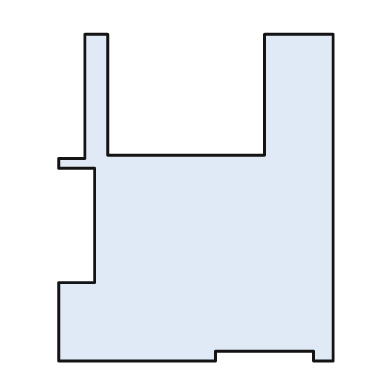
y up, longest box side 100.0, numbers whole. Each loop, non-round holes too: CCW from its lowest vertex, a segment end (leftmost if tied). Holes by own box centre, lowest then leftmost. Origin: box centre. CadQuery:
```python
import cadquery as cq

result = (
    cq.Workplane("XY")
    .moveTo(-42.0, -50.0)
    .lineTo(6.0, -50.0)
    .lineTo(6.0, -47.0)
    .lineTo(36.0, -47.0)
    .lineTo(36.0, -50.0)
    .lineTo(42.0, -50.0)
    .lineTo(42.0, 50.0)
    .lineTo(21.0, 50.0)
    .lineTo(21.0, 13.0)
    .lineTo(-27.0, 13.0)
    .lineTo(-27.0, 50.0)
    .lineTo(-34.0, 50.0)
    .lineTo(-34.0, 12.0)
    .lineTo(-42.0, 12.0)
    .lineTo(-42.0, 9.0)
    .lineTo(-31.0, 9.0)
    .lineTo(-31.0, -26.0)
    .lineTo(-42.0, -26.0)
    .close()
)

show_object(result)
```